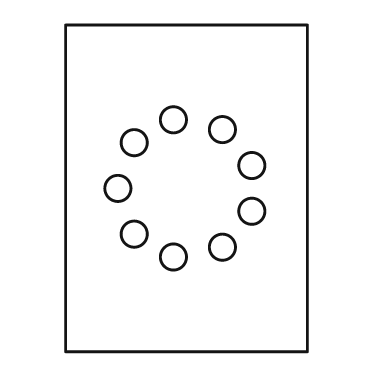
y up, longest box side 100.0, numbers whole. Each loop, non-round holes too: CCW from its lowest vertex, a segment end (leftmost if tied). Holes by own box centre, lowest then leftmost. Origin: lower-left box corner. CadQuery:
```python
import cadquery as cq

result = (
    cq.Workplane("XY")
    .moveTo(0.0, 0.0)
    .lineTo(74.0, 0.0)
    .lineTo(74.0, 100.0)
    .lineTo(0.0, 100.0)
    .close()
    .moveTo(33.0, 29.0)
    .circle(4.0)
    .moveTo(48.0, 32.0)
    .circle(4.0)
    .moveTo(21.0, 36.0)
    .circle(4.0)
    .moveTo(57.0, 43.0)
    .circle(4.0)
    .moveTo(16.0, 50.0)
    .circle(4.0)
    .moveTo(57.0, 57.0)
    .circle(4.0)
    .moveTo(21.0, 64.0)
    .circle(4.0)
    .moveTo(48.0, 68.0)
    .circle(4.0)
    .moveTo(33.0, 71.0)
    .circle(4.0)
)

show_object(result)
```